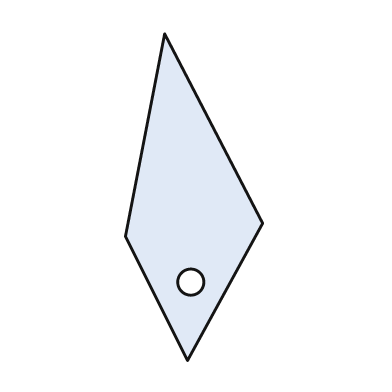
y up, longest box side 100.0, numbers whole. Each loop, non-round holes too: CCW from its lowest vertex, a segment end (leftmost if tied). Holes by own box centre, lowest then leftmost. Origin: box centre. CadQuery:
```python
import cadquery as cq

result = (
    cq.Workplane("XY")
    .moveTo(-2.0, -50.0)
    .lineTo(21.0, -8.0)
    .lineTo(-9.0, 50.0)
    .lineTo(-21.0, -12.0)
    .close()
    .moveTo(-1.0, -26.0)
    .circle(4.0)
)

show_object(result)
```